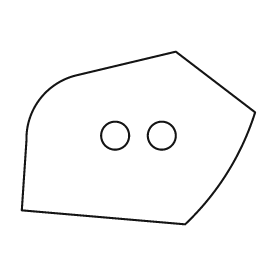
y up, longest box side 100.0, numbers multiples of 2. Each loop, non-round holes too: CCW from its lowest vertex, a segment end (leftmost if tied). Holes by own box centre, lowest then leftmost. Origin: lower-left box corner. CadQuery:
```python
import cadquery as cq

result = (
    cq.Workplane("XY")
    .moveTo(70.0, 0.0)
    .threePointArc((88.0, 22.0), (100.0, 48.0))
    .lineTo(66.0, 74.0)
    .lineTo(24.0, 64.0)
    .threePointArc((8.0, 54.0), (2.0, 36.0))
    .lineTo(0.0, 6.0)
    .close()
    .moveTo(40.0, 38.0)
    .circle(6.0)
    .moveTo(60.0, 38.0)
    .circle(6.0)
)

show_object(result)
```